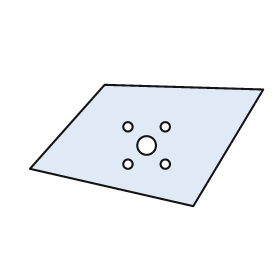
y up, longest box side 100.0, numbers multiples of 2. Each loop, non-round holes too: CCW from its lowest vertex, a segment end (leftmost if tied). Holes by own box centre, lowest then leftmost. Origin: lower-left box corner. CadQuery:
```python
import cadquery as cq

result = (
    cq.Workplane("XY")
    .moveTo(70.0, 0.0)
    .lineTo(100.0, 50.0)
    .lineTo(32.0, 52.0)
    .lineTo(0.0, 16.0)
    .close()
    .moveTo(42.0, 18.0)
    .circle(2.0)
    .moveTo(58.0, 18.0)
    .circle(2.0)
    .moveTo(50.0, 26.0)
    .circle(4.0)
    .moveTo(42.0, 34.0)
    .circle(2.0)
    .moveTo(58.0, 34.0)
    .circle(2.0)
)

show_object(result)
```